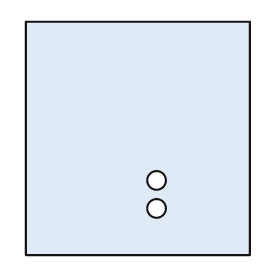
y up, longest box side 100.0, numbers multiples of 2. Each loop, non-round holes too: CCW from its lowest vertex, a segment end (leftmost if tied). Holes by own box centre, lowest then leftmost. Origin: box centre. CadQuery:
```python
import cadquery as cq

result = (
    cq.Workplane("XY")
    .moveTo(-48.0, -50.0)
    .lineTo(48.0, -50.0)
    .lineTo(48.0, 50.0)
    .lineTo(-48.0, 50.0)
    .close()
    .moveTo(8.0, -30.0)
    .circle(4.0)
    .moveTo(8.0, -18.0)
    .circle(4.0)
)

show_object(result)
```